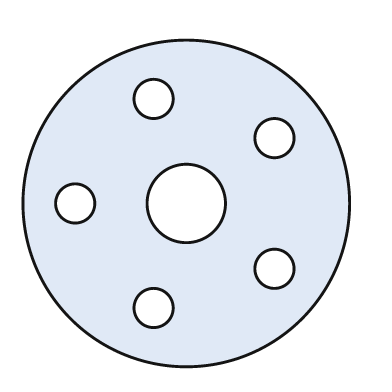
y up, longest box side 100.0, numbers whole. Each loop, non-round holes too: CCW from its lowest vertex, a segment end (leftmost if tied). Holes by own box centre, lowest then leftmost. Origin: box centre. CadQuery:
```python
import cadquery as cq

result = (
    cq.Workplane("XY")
    .moveTo(0.0, 0.0)
    .circle(50.0)
    .moveTo(-10.0, -32.0)
    .circle(6.0)
    .moveTo(27.0, -20.0)
    .circle(6.0)
    .moveTo(-34.0, 0.0)
    .circle(6.0)
    .moveTo(0.0, 0.0)
    .circle(12.0)
    .moveTo(27.0, 20.0)
    .circle(6.0)
    .moveTo(-10.0, 32.0)
    .circle(6.0)
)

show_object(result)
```